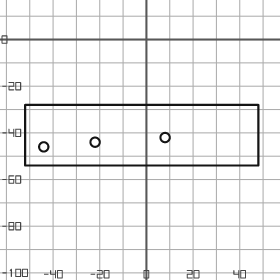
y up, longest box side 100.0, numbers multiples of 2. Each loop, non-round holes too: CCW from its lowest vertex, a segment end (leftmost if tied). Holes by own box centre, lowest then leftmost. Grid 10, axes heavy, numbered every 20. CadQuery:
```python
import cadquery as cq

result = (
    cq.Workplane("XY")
    .moveTo(-52.0, -54.0)
    .lineTo(48.0, -54.0)
    .lineTo(48.0, -28.0)
    .lineTo(-52.0, -28.0)
    .close()
    .moveTo(-44.0, -46.0)
    .circle(2.0)
    .moveTo(-22.0, -44.0)
    .circle(2.0)
    .moveTo(8.0, -42.0)
    .circle(2.0)
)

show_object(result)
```